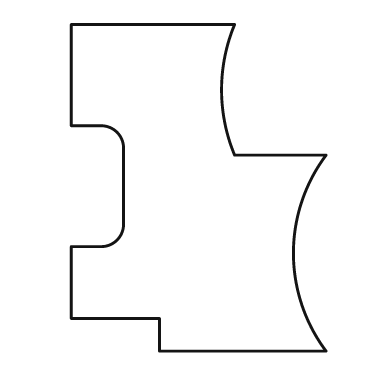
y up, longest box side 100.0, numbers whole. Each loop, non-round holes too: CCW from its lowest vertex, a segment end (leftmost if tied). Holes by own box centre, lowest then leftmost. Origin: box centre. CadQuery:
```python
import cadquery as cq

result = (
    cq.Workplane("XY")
    .moveTo(-12.0, -50.0)
    .lineTo(39.0, -50.0)
    .threePointArc((29.0, -20.0), (39.0, 10.0))
    .lineTo(11.0, 10.0)
    .threePointArc((7.0, 30.0), (11.0, 50.0))
    .lineTo(-39.0, 50.0)
    .lineTo(-39.0, 19.0)
    .lineTo(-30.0, 19.0)
    .threePointArc((-25.0, 17.0), (-23.0, 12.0))
    .lineTo(-23.0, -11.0)
    .threePointArc((-25.0, -16.0), (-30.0, -18.0))
    .lineTo(-39.0, -18.0)
    .lineTo(-39.0, -40.0)
    .lineTo(-12.0, -40.0)
    .close()
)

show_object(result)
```